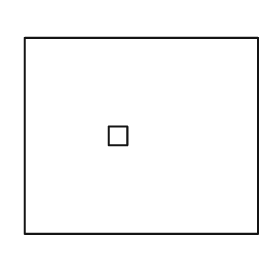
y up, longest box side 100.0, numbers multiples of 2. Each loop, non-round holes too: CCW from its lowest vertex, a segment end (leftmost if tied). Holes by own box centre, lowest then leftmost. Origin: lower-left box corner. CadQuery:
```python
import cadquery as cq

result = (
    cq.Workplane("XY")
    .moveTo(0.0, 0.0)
    .lineTo(100.0, 0.0)
    .lineTo(100.0, 84.0)
    .lineTo(0.0, 84.0)
    .close()
    .moveTo(36.0, 38.0)
    .lineTo(44.0, 38.0)
    .lineTo(44.0, 46.0)
    .lineTo(36.0, 46.0)
    .close()
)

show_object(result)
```